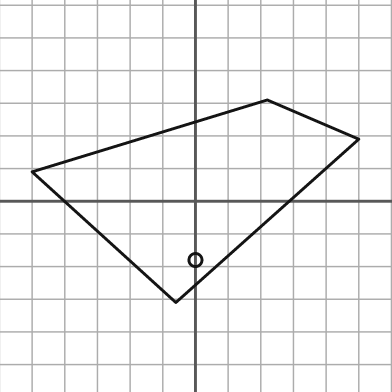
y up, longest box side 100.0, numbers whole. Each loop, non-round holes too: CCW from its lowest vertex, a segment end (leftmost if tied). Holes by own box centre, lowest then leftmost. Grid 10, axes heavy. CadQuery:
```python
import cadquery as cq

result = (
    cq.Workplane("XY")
    .moveTo(-6.0, -31.0)
    .lineTo(50.0, 19.0)
    .lineTo(22.0, 31.0)
    .lineTo(-50.0, 9.0)
    .close()
    .moveTo(0.0, -18.0)
    .circle(2.0)
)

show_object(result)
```